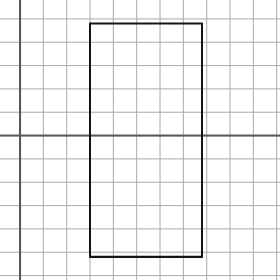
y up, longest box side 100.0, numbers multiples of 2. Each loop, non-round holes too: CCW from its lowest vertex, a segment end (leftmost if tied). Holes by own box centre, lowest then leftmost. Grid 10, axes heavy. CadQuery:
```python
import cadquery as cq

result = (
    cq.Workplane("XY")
    .moveTo(30.0, -52.0)
    .lineTo(78.0, -52.0)
    .lineTo(78.0, 48.0)
    .lineTo(30.0, 48.0)
    .close()
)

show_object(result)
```